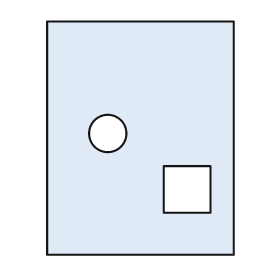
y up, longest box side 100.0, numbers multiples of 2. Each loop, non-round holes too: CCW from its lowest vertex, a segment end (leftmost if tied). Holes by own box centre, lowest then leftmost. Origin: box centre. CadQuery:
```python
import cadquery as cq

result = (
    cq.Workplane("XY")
    .moveTo(-40.0, -50.0)
    .lineTo(40.0, -50.0)
    .lineTo(40.0, 50.0)
    .lineTo(-40.0, 50.0)
    .close()
    .moveTo(10.0, -32.0)
    .lineTo(30.0, -32.0)
    .lineTo(30.0, -12.0)
    .lineTo(10.0, -12.0)
    .close()
    .moveTo(-14.0, 2.0)
    .circle(8.0)
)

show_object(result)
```